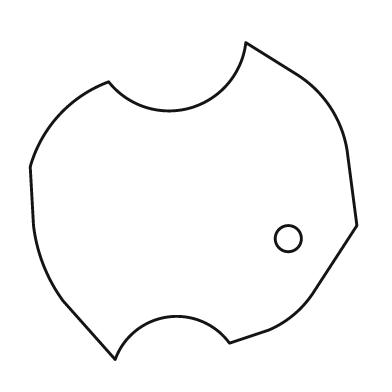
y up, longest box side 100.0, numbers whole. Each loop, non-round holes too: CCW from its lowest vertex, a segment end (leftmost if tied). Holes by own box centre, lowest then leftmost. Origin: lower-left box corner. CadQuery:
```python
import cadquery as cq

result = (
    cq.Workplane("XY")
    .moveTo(26.0, 0.0)
    .threePointArc((42.0, 13.0), (61.0, 5.0))
    .lineTo(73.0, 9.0)
    .threePointArc((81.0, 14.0), (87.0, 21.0))
    .lineTo(100.0, 41.0)
    .lineTo(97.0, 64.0)
    .threePointArc((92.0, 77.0), (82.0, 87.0))
    .lineTo(66.0, 97.0)
    .threePointArc((49.0, 77.0), (24.0, 85.0))
    .threePointArc((9.0, 75.0), (0.0, 59.0))
    .lineTo(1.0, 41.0)
    .threePointArc((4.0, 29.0), (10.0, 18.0))
    .close()
    .moveTo(79.0, 37.0)
    .circle(4.0)
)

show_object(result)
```